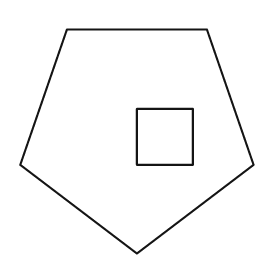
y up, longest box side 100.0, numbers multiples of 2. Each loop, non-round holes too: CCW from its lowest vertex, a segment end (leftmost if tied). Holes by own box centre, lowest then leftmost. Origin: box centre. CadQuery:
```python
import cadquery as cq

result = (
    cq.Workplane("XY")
    .moveTo(0.0, -48.0)
    .lineTo(50.0, -10.0)
    .lineTo(30.0, 48.0)
    .lineTo(-30.0, 48.0)
    .lineTo(-50.0, -10.0)
    .close()
    .moveTo(0.0, -10.0)
    .lineTo(24.0, -10.0)
    .lineTo(24.0, 14.0)
    .lineTo(0.0, 14.0)
    .close()
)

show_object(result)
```